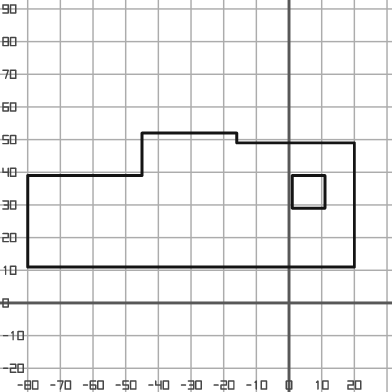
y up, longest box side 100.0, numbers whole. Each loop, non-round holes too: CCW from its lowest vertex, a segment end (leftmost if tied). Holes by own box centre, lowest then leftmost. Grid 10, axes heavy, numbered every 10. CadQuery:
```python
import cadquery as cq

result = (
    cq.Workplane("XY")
    .moveTo(-80.0, 11.0)
    .lineTo(20.0, 11.0)
    .lineTo(20.0, 49.0)
    .lineTo(-16.0, 49.0)
    .lineTo(-16.0, 52.0)
    .lineTo(-45.0, 52.0)
    .lineTo(-45.0, 39.0)
    .lineTo(-80.0, 39.0)
    .close()
    .moveTo(1.0, 29.0)
    .lineTo(11.0, 29.0)
    .lineTo(11.0, 39.0)
    .lineTo(1.0, 39.0)
    .close()
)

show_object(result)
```